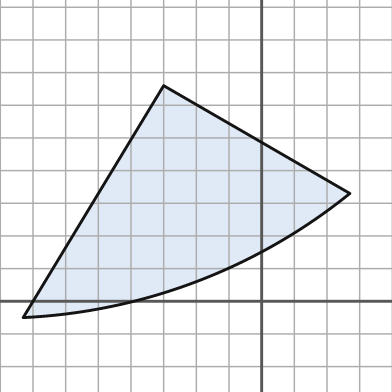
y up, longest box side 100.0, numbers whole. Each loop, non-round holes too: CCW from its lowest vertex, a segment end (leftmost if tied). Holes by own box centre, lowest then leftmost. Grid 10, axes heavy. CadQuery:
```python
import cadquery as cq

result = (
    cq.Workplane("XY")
    .moveTo(-73.0, -5.0)
    .threePointArc((-20.0, 6.0), (27.0, 33.0))
    .lineTo(-30.0, 66.0)
    .close()
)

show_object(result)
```